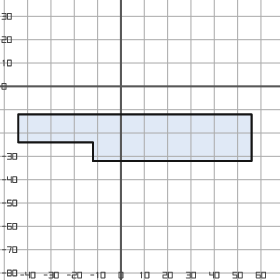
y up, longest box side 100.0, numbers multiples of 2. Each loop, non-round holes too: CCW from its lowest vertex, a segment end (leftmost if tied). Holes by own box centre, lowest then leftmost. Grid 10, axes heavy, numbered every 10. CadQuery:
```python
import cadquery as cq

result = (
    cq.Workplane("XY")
    .moveTo(-12.0, -32.0)
    .lineTo(56.0, -32.0)
    .lineTo(56.0, -12.0)
    .lineTo(-44.0, -12.0)
    .lineTo(-44.0, -24.0)
    .lineTo(-12.0, -24.0)
    .close()
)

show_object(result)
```